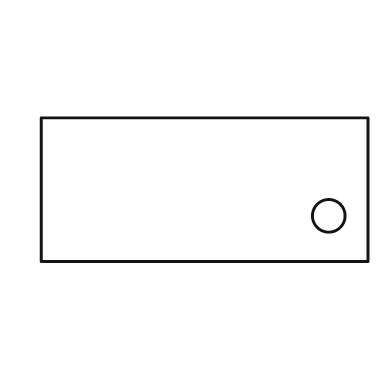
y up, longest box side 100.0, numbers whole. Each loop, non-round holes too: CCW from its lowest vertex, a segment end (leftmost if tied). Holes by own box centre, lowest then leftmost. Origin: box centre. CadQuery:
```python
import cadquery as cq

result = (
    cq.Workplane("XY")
    .moveTo(-50.0, -22.0)
    .lineTo(50.0, -22.0)
    .lineTo(50.0, 22.0)
    .lineTo(-50.0, 22.0)
    .close()
    .moveTo(38.0, -8.0)
    .circle(5.0)
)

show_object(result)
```